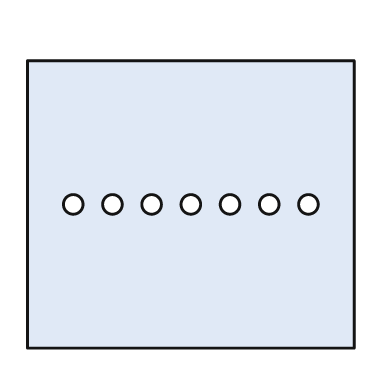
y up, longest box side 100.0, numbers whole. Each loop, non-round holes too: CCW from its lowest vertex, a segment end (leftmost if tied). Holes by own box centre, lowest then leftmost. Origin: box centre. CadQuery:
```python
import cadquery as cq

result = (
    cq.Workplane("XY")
    .moveTo(-50.0, -44.0)
    .lineTo(50.0, -44.0)
    .lineTo(50.0, 44.0)
    .lineTo(-50.0, 44.0)
    .close()
    .moveTo(-36.0, 0.0)
    .circle(3.0)
    .moveTo(-24.0, 0.0)
    .circle(3.0)
    .moveTo(-12.0, 0.0)
    .circle(3.0)
    .moveTo(0.0, 0.0)
    .circle(3.0)
    .moveTo(12.0, 0.0)
    .circle(3.0)
    .moveTo(24.0, 0.0)
    .circle(3.0)
    .moveTo(36.0, 0.0)
    .circle(3.0)
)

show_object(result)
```